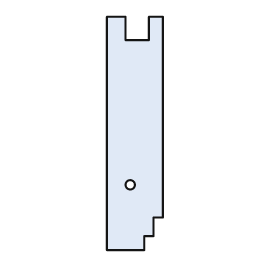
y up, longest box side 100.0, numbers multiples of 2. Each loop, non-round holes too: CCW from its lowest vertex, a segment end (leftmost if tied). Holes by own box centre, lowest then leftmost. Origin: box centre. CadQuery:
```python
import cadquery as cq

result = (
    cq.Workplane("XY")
    .moveTo(-12.0, -50.0)
    .lineTo(4.0, -50.0)
    .lineTo(4.0, -44.0)
    .lineTo(8.0, -44.0)
    .lineTo(8.0, -36.0)
    .lineTo(12.0, -36.0)
    .lineTo(12.0, 50.0)
    .lineTo(6.0, 50.0)
    .lineTo(6.0, 40.0)
    .lineTo(-4.0, 40.0)
    .lineTo(-4.0, 50.0)
    .lineTo(-12.0, 50.0)
    .close()
    .moveTo(-2.0, -22.0)
    .circle(2.0)
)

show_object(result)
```